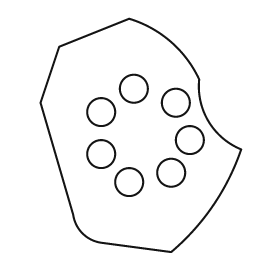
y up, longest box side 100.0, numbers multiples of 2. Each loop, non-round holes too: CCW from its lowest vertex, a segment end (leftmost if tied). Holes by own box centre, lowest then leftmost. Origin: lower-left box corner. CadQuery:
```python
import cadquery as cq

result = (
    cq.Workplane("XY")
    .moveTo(56.0, 0.0)
    .threePointArc((74.0, 20.0), (86.0, 44.0))
    .threePointArc((72.0, 56.0), (68.0, 74.0))
    .threePointArc((56.0, 90.0), (38.0, 100.0))
    .lineTo(8.0, 88.0)
    .lineTo(0.0, 64.0)
    .lineTo(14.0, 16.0)
    .threePointArc((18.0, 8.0), (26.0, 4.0))
    .close()
    .moveTo(38.0, 30.0)
    .circle(6.0)
    .moveTo(56.0, 34.0)
    .circle(6.0)
    .moveTo(26.0, 42.0)
    .circle(6.0)
    .moveTo(64.0, 48.0)
    .circle(6.0)
    .moveTo(26.0, 60.0)
    .circle(6.0)
    .moveTo(58.0, 64.0)
    .circle(6.0)
    .moveTo(40.0, 70.0)
    .circle(6.0)
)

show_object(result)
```